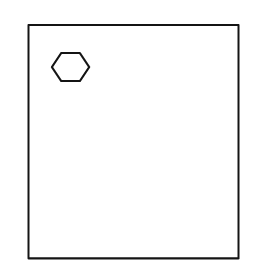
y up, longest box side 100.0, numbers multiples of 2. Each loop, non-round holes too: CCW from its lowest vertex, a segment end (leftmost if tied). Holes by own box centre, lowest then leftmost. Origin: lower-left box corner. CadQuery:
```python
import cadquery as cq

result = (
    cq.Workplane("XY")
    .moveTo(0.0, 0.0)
    .lineTo(90.0, 0.0)
    .lineTo(90.0, 100.0)
    .lineTo(0.0, 100.0)
    .close()
    .moveTo(14.0, 76.0)
    .lineTo(22.0, 76.0)
    .lineTo(26.0, 82.0)
    .lineTo(22.0, 88.0)
    .lineTo(14.0, 88.0)
    .lineTo(10.0, 82.0)
    .close()
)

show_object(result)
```